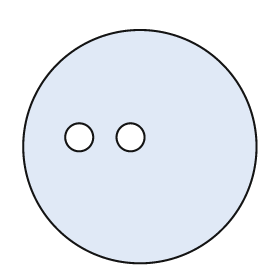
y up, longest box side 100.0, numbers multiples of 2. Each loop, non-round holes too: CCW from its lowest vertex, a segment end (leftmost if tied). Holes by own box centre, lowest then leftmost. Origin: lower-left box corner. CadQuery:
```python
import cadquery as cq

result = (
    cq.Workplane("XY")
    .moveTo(50.0, 50.0)
    .circle(50.0)
    .moveTo(24.0, 54.0)
    .circle(6.0)
    .moveTo(46.0, 54.0)
    .circle(6.0)
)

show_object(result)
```